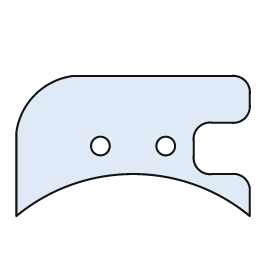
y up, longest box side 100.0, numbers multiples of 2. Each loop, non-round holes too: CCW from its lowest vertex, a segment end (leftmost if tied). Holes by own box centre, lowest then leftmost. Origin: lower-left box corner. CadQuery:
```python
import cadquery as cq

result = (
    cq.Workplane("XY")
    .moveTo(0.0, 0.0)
    .threePointArc((50.0, 18.0), (100.0, 0.0))
    .lineTo(100.0, 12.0)
    .threePointArc((98.0, 16.0), (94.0, 18.0))
    .lineTo(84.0, 18.0)
    .threePointArc((78.0, 20.0), (76.0, 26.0))
    .lineTo(76.0, 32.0)
    .threePointArc((78.0, 38.0), (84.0, 40.0))
    .lineTo(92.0, 40.0)
    .threePointArc((98.0, 42.0), (100.0, 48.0))
    .lineTo(100.0, 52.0)
    .threePointArc((98.0, 58.0), (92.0, 60.0))
    .lineTo(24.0, 60.0)
    .threePointArc((8.0, 52.0), (0.0, 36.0))
    .close()
    .moveTo(36.0, 30.0)
    .circle(4.0)
    .moveTo(64.0, 30.0)
    .circle(4.0)
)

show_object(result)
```